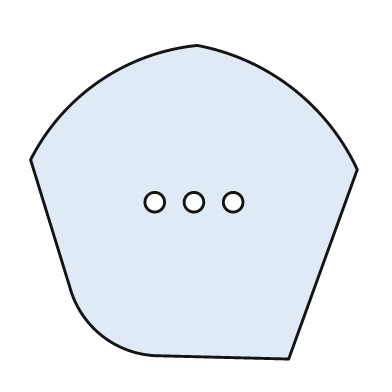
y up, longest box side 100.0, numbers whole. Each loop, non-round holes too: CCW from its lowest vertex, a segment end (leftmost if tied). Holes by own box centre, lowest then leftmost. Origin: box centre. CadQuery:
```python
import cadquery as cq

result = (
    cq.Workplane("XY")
    .moveTo(29.0, -48.0)
    .lineTo(50.0, 10.0)
    .threePointArc((30.0, 35.0), (1.0, 48.0))
    .threePointArc((-29.0, 37.0), (-50.0, 13.0))
    .lineTo(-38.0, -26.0)
    .threePointArc((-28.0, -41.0), (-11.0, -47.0))
    .close()
    .moveTo(-12.0, 0.0)
    .circle(3.0)
    .moveTo(0.0, 0.0)
    .circle(3.0)
    .moveTo(12.0, 0.0)
    .circle(3.0)
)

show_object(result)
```